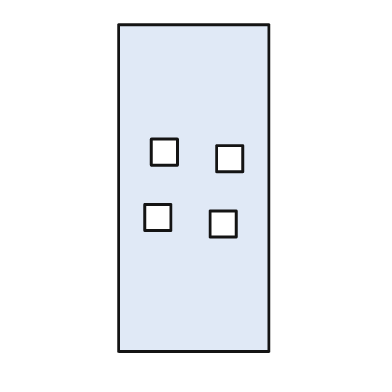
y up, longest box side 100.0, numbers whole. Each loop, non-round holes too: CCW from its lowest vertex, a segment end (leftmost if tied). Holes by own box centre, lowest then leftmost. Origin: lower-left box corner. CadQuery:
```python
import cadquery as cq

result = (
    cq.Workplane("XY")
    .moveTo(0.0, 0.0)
    .lineTo(46.0, 0.0)
    .lineTo(46.0, 100.0)
    .lineTo(0.0, 100.0)
    .close()
    .moveTo(28.0, 35.0)
    .lineTo(36.0, 35.0)
    .lineTo(36.0, 43.0)
    .lineTo(28.0, 43.0)
    .close()
    .moveTo(8.0, 37.0)
    .lineTo(16.0, 37.0)
    .lineTo(16.0, 45.0)
    .lineTo(8.0, 45.0)
    .close()
    .moveTo(30.0, 55.0)
    .lineTo(38.0, 55.0)
    .lineTo(38.0, 63.0)
    .lineTo(30.0, 63.0)
    .close()
    .moveTo(10.0, 57.0)
    .lineTo(18.0, 57.0)
    .lineTo(18.0, 65.0)
    .lineTo(10.0, 65.0)
    .close()
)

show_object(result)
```